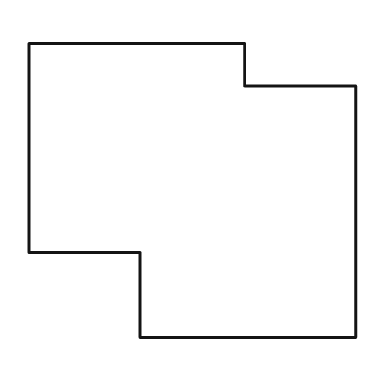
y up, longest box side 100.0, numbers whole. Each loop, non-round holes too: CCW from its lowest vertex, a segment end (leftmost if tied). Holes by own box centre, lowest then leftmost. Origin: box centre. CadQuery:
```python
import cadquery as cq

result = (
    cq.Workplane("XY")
    .moveTo(-16.0, -45.0)
    .lineTo(50.0, -45.0)
    .lineTo(50.0, 32.0)
    .lineTo(16.0, 32.0)
    .lineTo(16.0, 45.0)
    .lineTo(-50.0, 45.0)
    .lineTo(-50.0, -19.0)
    .lineTo(-16.0, -19.0)
    .close()
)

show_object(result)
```